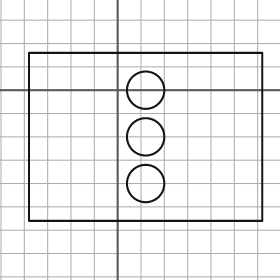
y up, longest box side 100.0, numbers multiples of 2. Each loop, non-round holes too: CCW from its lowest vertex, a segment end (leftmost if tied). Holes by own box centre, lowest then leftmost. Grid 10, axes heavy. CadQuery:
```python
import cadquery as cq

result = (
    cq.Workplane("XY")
    .moveTo(-38.0, -56.0)
    .lineTo(62.0, -56.0)
    .lineTo(62.0, 16.0)
    .lineTo(-38.0, 16.0)
    .close()
    .moveTo(12.0, -40.0)
    .circle(8.0)
    .moveTo(12.0, -20.0)
    .circle(8.0)
    .moveTo(12.0, 0.0)
    .circle(8.0)
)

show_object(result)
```